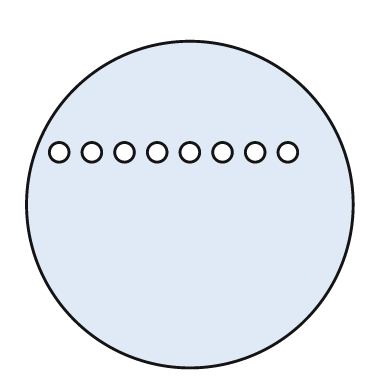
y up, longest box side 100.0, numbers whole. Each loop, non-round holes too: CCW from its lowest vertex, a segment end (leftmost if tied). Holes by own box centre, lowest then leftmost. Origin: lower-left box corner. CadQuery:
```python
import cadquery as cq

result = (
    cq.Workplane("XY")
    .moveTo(50.0, 50.0)
    .circle(50.0)
    .moveTo(10.0, 66.0)
    .circle(3.0)
    .moveTo(20.0, 66.0)
    .circle(3.0)
    .moveTo(30.0, 66.0)
    .circle(3.0)
    .moveTo(40.0, 66.0)
    .circle(3.0)
    .moveTo(50.0, 66.0)
    .circle(3.0)
    .moveTo(60.0, 66.0)
    .circle(3.0)
    .moveTo(70.0, 66.0)
    .circle(3.0)
    .moveTo(80.0, 66.0)
    .circle(3.0)
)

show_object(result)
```